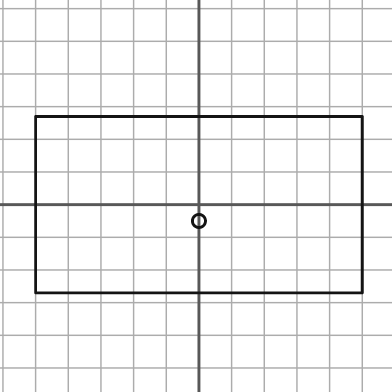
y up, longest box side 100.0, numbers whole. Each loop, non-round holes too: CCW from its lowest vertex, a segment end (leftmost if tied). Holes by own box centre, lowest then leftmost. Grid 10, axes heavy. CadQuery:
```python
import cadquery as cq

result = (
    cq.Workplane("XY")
    .moveTo(-50.0, -27.0)
    .lineTo(50.0, -27.0)
    .lineTo(50.0, 27.0)
    .lineTo(-50.0, 27.0)
    .close()
    .moveTo(0.0, -5.0)
    .circle(2.0)
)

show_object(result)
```